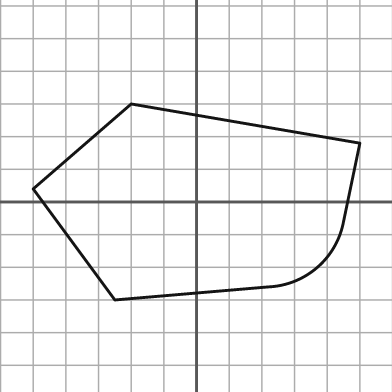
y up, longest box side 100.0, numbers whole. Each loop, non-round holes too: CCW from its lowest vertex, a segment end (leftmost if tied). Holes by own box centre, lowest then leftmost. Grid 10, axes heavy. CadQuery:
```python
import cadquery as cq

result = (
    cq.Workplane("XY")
    .moveTo(-25.0, -30.0)
    .lineTo(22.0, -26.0)
    .threePointArc((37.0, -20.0), (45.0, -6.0))
    .lineTo(50.0, 18.0)
    .lineTo(-20.0, 30.0)
    .lineTo(-50.0, 4.0)
    .close()
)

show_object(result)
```